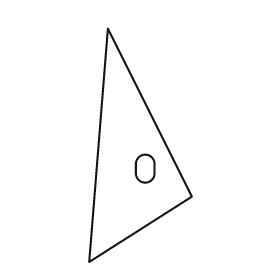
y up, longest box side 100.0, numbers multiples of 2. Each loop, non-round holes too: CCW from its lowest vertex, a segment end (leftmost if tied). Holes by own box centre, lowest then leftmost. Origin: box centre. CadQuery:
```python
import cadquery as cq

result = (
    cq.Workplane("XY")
    .moveTo(-22.0, -50.0)
    .lineTo(22.0, -22.0)
    .lineTo(-14.0, 50.0)
    .close()
    .moveTo(-2.0, -12.0)
    .threePointArc((2.0, -16.0), (6.0, -12.0))
    .lineTo(6.0, -8.0)
    .threePointArc((2.0, -4.0), (-2.0, -8.0))
    .close()
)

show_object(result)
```